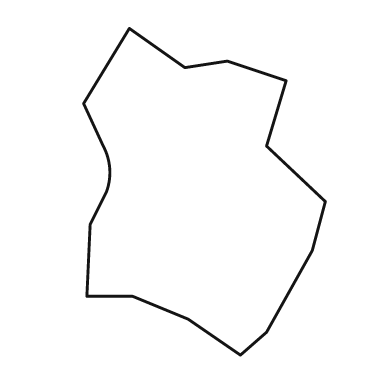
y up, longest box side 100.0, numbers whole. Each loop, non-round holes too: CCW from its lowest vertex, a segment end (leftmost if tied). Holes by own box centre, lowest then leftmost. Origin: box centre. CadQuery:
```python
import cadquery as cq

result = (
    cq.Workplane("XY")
    .moveTo(11.0, -50.0)
    .lineTo(19.0, -43.0)
    .lineTo(33.0, -18.0)
    .lineTo(37.0, -3.0)
    .lineTo(19.0, 14.0)
    .lineTo(25.0, 34.0)
    .lineTo(7.0, 40.0)
    .lineTo(-6.0, 38.0)
    .lineTo(-23.0, 50.0)
    .lineTo(-37.0, 27.0)
    .lineTo(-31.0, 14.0)
    .threePointArc((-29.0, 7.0), (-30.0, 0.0))
    .lineTo(-35.0, -10.0)
    .lineTo(-36.0, -32.0)
    .lineTo(-22.0, -32.0)
    .lineTo(-5.0, -39.0)
    .close()
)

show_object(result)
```